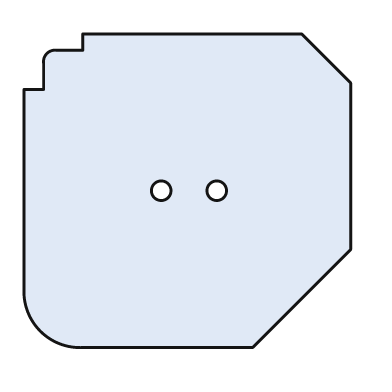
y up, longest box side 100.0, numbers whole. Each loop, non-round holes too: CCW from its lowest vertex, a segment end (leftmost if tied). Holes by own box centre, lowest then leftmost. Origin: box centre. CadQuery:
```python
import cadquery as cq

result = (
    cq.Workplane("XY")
    .moveTo(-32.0, -48.0)
    .lineTo(20.0, -48.0)
    .lineTo(50.0, -18.0)
    .lineTo(50.0, 33.0)
    .lineTo(35.0, 48.0)
    .lineTo(-32.0, 48.0)
    .lineTo(-32.0, 43.0)
    .lineTo(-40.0, 43.0)
    .threePointArc((-43.0, 42.0), (-44.0, 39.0))
    .lineTo(-44.0, 31.0)
    .lineTo(-50.0, 31.0)
    .lineTo(-50.0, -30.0)
    .threePointArc((-45.0, -43.0), (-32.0, -48.0))
    .close()
    .moveTo(-8.0, 0.0)
    .circle(3.0)
    .moveTo(9.0, 0.0)
    .circle(3.0)
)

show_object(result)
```